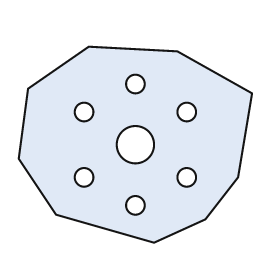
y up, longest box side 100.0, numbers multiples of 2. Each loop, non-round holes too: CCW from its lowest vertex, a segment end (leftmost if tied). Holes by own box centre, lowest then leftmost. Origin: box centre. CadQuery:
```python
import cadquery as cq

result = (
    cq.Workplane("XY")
    .moveTo(8.0, -42.0)
    .lineTo(30.0, -32.0)
    .lineTo(44.0, -14.0)
    .lineTo(50.0, 22.0)
    .lineTo(18.0, 40.0)
    .lineTo(-20.0, 42.0)
    .lineTo(-46.0, 24.0)
    .lineTo(-50.0, -6.0)
    .lineTo(-34.0, -30.0)
    .close()
    .moveTo(0.0, -26.0)
    .circle(4.0)
    .moveTo(-22.0, -14.0)
    .circle(4.0)
    .moveTo(22.0, -14.0)
    .circle(4.0)
    .moveTo(0.0, 0.0)
    .circle(8.0)
    .moveTo(-22.0, 14.0)
    .circle(4.0)
    .moveTo(22.0, 14.0)
    .circle(4.0)
    .moveTo(0.0, 26.0)
    .circle(4.0)
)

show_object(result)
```